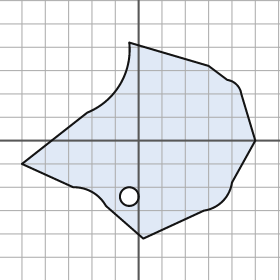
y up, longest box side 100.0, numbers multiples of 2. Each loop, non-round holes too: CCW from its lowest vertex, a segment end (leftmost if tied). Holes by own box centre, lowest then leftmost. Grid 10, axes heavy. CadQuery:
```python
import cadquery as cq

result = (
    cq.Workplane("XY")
    .moveTo(2.0, -42.0)
    .lineTo(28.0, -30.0)
    .threePointArc((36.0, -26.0), (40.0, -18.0))
    .lineTo(50.0, 0.0)
    .lineTo(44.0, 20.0)
    .threePointArc((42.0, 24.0), (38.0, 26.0))
    .lineTo(30.0, 32.0)
    .lineTo(-4.0, 42.0)
    .threePointArc((-8.0, 24.0), (-22.0, 12.0))
    .lineTo(-50.0, -10.0)
    .lineTo(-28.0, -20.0)
    .threePointArc((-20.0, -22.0), (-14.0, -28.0))
    .close()
    .moveTo(-4.0, -24.0)
    .circle(4.0)
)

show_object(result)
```